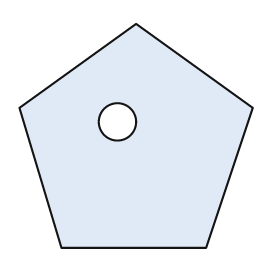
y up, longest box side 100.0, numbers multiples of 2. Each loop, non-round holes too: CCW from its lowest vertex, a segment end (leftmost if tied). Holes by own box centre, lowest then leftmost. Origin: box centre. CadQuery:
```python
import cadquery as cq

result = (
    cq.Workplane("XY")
    .moveTo(-32.0, -48.0)
    .lineTo(30.0, -48.0)
    .lineTo(50.0, 12.0)
    .lineTo(0.0, 48.0)
    .lineTo(-50.0, 12.0)
    .close()
    .moveTo(-8.0, 6.0)
    .circle(8.0)
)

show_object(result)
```